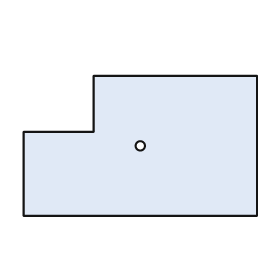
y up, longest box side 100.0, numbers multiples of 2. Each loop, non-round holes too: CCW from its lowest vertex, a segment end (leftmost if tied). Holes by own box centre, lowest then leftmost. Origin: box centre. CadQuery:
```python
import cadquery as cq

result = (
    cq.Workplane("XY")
    .moveTo(-50.0, -30.0)
    .lineTo(50.0, -30.0)
    .lineTo(50.0, 30.0)
    .lineTo(-20.0, 30.0)
    .lineTo(-20.0, 6.0)
    .lineTo(-50.0, 6.0)
    .close()
    .moveTo(0.0, 0.0)
    .circle(2.0)
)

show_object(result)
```